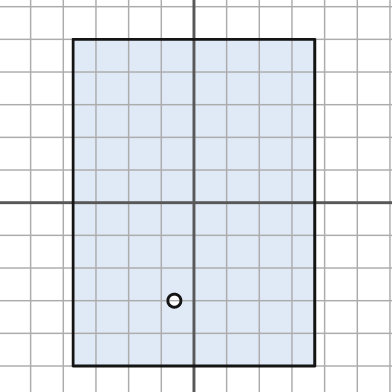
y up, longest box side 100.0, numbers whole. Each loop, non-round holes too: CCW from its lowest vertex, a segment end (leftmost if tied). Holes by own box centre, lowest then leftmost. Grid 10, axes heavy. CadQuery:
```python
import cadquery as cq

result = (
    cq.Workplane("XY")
    .moveTo(-37.0, -50.0)
    .lineTo(37.0, -50.0)
    .lineTo(37.0, 50.0)
    .lineTo(-37.0, 50.0)
    .close()
    .moveTo(-6.0, -30.0)
    .circle(2.0)
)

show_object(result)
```